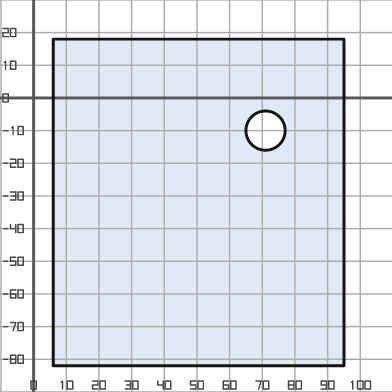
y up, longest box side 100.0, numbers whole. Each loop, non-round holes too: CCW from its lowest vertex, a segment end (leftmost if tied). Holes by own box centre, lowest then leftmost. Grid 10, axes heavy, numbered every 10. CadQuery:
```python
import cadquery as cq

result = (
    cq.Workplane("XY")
    .moveTo(6.0, -82.0)
    .lineTo(95.0, -82.0)
    .lineTo(95.0, 18.0)
    .lineTo(6.0, 18.0)
    .close()
    .moveTo(71.0, -10.0)
    .circle(6.0)
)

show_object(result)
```